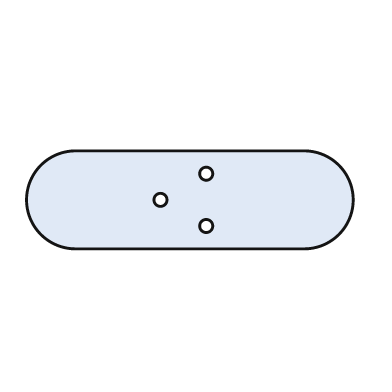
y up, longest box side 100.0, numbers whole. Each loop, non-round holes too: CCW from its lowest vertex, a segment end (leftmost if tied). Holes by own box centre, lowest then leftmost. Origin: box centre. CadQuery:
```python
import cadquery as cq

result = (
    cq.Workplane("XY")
    .moveTo(-35.0, -15.0)
    .lineTo(35.0, -15.0)
    .threePointArc((50.0, 0.0), (35.0, 15.0))
    .lineTo(-35.0, 15.0)
    .threePointArc((-50.0, 0.0), (-35.0, -15.0))
    .close()
    .moveTo(5.0, -8.0)
    .circle(2.0)
    .moveTo(-9.0, 0.0)
    .circle(2.0)
    .moveTo(5.0, 8.0)
    .circle(2.0)
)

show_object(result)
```